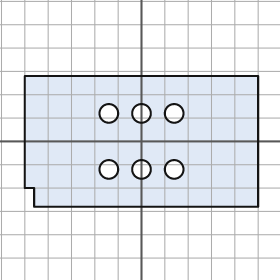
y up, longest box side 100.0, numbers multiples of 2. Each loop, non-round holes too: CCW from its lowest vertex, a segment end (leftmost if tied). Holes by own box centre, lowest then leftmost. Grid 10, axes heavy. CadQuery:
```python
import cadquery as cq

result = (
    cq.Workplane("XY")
    .moveTo(-46.0, -28.0)
    .lineTo(50.0, -28.0)
    .lineTo(50.0, 28.0)
    .lineTo(-50.0, 28.0)
    .lineTo(-50.0, -20.0)
    .lineTo(-46.0, -20.0)
    .close()
    .moveTo(-14.0, -12.0)
    .circle(4.0)
    .moveTo(0.0, -12.0)
    .circle(4.0)
    .moveTo(14.0, -12.0)
    .circle(4.0)
    .moveTo(-14.0, 12.0)
    .circle(4.0)
    .moveTo(0.0, 12.0)
    .circle(4.0)
    .moveTo(14.0, 12.0)
    .circle(4.0)
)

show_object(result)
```